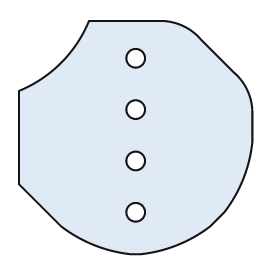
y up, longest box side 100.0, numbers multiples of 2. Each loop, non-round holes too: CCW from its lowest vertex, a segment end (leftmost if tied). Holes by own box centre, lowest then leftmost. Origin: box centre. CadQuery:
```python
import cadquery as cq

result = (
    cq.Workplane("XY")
    .moveTo(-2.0, -50.0)
    .lineTo(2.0, -50.0)
    .threePointArc((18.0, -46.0), (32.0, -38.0))
    .lineTo(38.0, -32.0)
    .threePointArc((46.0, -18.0), (50.0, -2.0))
    .lineTo(50.0, 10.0)
    .threePointArc((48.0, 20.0), (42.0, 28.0))
    .lineTo(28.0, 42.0)
    .threePointArc((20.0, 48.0), (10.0, 50.0))
    .lineTo(-20.0, 50.0)
    .threePointArc((-32.0, 32.0), (-50.0, 20.0))
    .lineTo(-50.0, -20.0)
    .lineTo(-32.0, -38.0)
    .threePointArc((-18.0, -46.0), (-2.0, -50.0))
    .close()
    .moveTo(0.0, -32.0)
    .circle(4.0)
    .moveTo(0.0, -10.0)
    .circle(4.0)
    .moveTo(0.0, 12.0)
    .circle(4.0)
    .moveTo(0.0, 34.0)
    .circle(4.0)
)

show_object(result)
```